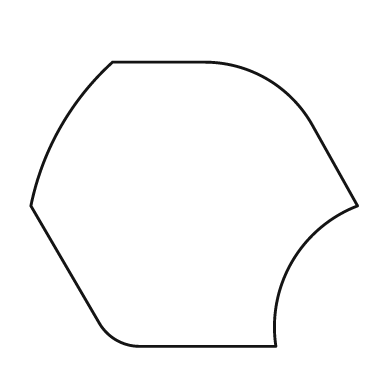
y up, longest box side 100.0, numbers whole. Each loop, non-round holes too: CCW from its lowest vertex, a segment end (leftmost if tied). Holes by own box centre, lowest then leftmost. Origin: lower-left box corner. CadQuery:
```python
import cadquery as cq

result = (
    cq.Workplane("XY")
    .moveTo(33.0, 0.0)
    .lineTo(75.0, 0.0)
    .threePointArc((80.0, 26.0), (100.0, 43.0))
    .lineTo(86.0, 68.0)
    .threePointArc((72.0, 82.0), (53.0, 87.0))
    .lineTo(25.0, 87.0)
    .threePointArc((9.0, 67.0), (0.0, 43.0))
    .lineTo(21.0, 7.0)
    .threePointArc((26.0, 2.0), (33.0, 0.0))
    .close()
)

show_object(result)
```